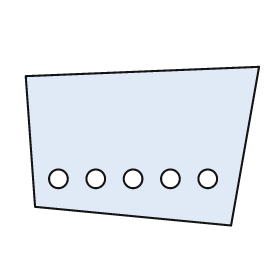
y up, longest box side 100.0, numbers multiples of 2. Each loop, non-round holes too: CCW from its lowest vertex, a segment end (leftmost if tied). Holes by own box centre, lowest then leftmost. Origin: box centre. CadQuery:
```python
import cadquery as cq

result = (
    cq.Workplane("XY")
    .moveTo(38.0, -34.0)
    .lineTo(50.0, 34.0)
    .lineTo(-50.0, 30.0)
    .lineTo(-46.0, -26.0)
    .close()
    .moveTo(-36.0, -14.0)
    .circle(4.0)
    .moveTo(-20.0, -14.0)
    .circle(4.0)
    .moveTo(-4.0, -14.0)
    .circle(4.0)
    .moveTo(12.0, -14.0)
    .circle(4.0)
    .moveTo(28.0, -14.0)
    .circle(4.0)
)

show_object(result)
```